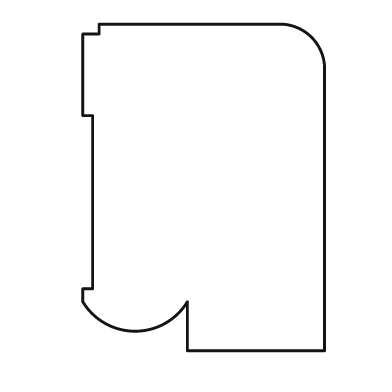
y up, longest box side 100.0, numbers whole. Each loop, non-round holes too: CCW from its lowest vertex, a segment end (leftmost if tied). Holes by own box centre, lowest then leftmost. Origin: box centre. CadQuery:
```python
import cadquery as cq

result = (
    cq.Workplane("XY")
    .moveTo(-5.0, -50.0)
    .lineTo(37.0, -50.0)
    .lineTo(37.0, 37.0)
    .threePointArc((33.0, 46.0), (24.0, 50.0))
    .lineTo(-32.0, 50.0)
    .lineTo(-32.0, 47.0)
    .lineTo(-37.0, 47.0)
    .lineTo(-37.0, 22.0)
    .lineTo(-34.0, 22.0)
    .lineTo(-34.0, -31.0)
    .lineTo(-37.0, -31.0)
    .lineTo(-37.0, -35.0)
    .threePointArc((-21.0, -44.0), (-5.0, -35.0))
    .close()
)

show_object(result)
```